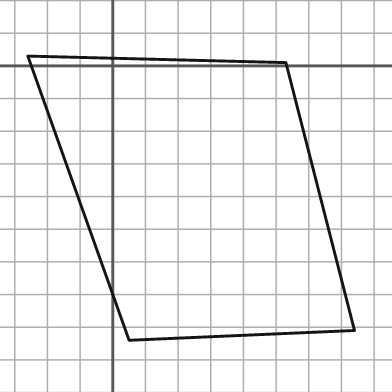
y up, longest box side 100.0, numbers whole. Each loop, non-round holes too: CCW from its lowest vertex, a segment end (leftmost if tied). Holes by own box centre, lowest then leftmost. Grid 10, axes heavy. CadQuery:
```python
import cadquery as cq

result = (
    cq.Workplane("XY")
    .moveTo(5.0, -84.0)
    .lineTo(74.0, -81.0)
    .lineTo(53.0, 1.0)
    .lineTo(-26.0, 3.0)
    .close()
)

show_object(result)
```